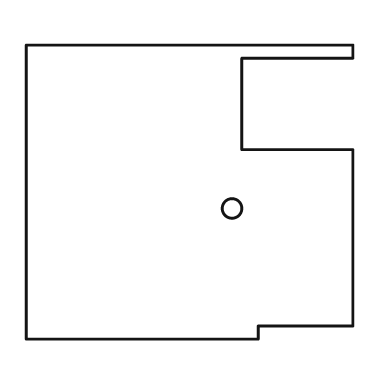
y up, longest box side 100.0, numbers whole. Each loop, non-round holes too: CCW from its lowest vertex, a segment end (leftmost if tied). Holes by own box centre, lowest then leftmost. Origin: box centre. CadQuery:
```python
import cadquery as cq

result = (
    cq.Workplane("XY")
    .moveTo(-50.0, -45.0)
    .lineTo(21.0, -45.0)
    .lineTo(21.0, -41.0)
    .lineTo(50.0, -41.0)
    .lineTo(50.0, 13.0)
    .lineTo(16.0, 13.0)
    .lineTo(16.0, 41.0)
    .lineTo(50.0, 41.0)
    .lineTo(50.0, 45.0)
    .lineTo(-50.0, 45.0)
    .close()
    .moveTo(13.0, -5.0)
    .circle(3.0)
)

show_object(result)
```